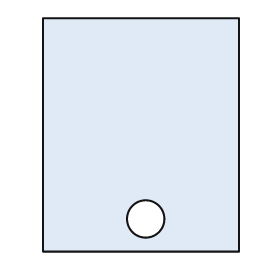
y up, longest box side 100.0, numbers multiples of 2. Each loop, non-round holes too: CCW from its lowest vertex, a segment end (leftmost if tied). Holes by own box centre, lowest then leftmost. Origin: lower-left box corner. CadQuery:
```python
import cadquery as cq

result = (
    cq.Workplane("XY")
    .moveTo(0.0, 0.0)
    .lineTo(84.0, 0.0)
    .lineTo(84.0, 100.0)
    .lineTo(0.0, 100.0)
    .close()
    .moveTo(44.0, 14.0)
    .circle(8.0)
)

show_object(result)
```